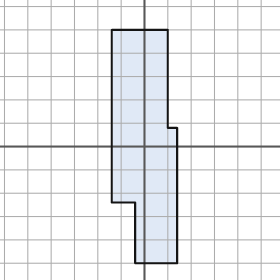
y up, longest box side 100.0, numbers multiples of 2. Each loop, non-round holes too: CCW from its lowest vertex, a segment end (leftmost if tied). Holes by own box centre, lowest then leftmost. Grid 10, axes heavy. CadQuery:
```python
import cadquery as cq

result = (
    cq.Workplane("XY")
    .moveTo(-4.0, -50.0)
    .lineTo(14.0, -50.0)
    .lineTo(14.0, 8.0)
    .lineTo(10.0, 8.0)
    .lineTo(10.0, 50.0)
    .lineTo(-14.0, 50.0)
    .lineTo(-14.0, -24.0)
    .lineTo(-4.0, -24.0)
    .close()
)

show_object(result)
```